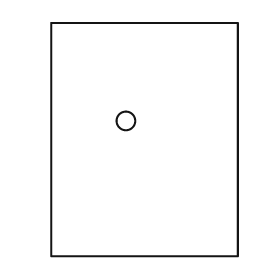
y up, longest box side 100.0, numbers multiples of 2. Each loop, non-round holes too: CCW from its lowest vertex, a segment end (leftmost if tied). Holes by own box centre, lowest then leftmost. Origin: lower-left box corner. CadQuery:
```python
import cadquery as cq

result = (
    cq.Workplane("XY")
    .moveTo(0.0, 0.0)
    .lineTo(80.0, 0.0)
    .lineTo(80.0, 100.0)
    .lineTo(0.0, 100.0)
    .close()
    .moveTo(32.0, 58.0)
    .circle(4.0)
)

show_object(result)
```